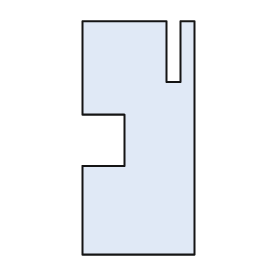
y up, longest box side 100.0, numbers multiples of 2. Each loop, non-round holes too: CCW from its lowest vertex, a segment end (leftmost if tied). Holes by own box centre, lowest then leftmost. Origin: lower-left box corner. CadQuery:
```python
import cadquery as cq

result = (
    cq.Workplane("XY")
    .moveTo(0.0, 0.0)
    .lineTo(48.0, 0.0)
    .lineTo(48.0, 100.0)
    .lineTo(42.0, 100.0)
    .lineTo(42.0, 74.0)
    .lineTo(36.0, 74.0)
    .lineTo(36.0, 100.0)
    .lineTo(0.0, 100.0)
    .lineTo(0.0, 60.0)
    .lineTo(18.0, 60.0)
    .lineTo(18.0, 38.0)
    .lineTo(0.0, 38.0)
    .close()
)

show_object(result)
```